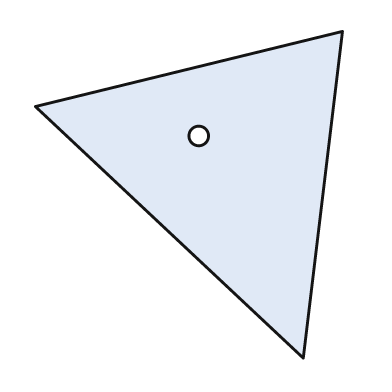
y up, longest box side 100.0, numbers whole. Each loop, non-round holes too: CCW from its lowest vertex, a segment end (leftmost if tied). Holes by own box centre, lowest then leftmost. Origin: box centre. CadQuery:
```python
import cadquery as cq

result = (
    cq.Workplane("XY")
    .moveTo(35.0, -50.0)
    .lineTo(47.0, 50.0)
    .lineTo(-47.0, 27.0)
    .close()
    .moveTo(3.0, 18.0)
    .circle(3.0)
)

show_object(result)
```